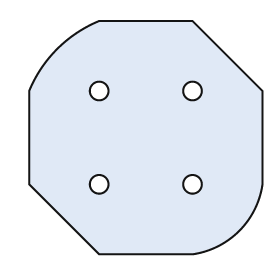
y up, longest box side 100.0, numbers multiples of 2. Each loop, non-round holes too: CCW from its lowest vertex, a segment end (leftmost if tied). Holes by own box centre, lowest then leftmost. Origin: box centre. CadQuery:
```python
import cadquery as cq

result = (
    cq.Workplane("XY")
    .moveTo(-20.0, -50.0)
    .lineTo(20.0, -50.0)
    .threePointArc((40.0, -40.0), (50.0, -20.0))
    .lineTo(50.0, 20.0)
    .lineTo(20.0, 50.0)
    .lineTo(-20.0, 50.0)
    .threePointArc((-38.0, 38.0), (-50.0, 20.0))
    .lineTo(-50.0, -20.0)
    .close()
    .moveTo(-20.0, -20.0)
    .circle(4.0)
    .moveTo(20.0, -20.0)
    .circle(4.0)
    .moveTo(-20.0, 20.0)
    .circle(4.0)
    .moveTo(20.0, 20.0)
    .circle(4.0)
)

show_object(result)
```